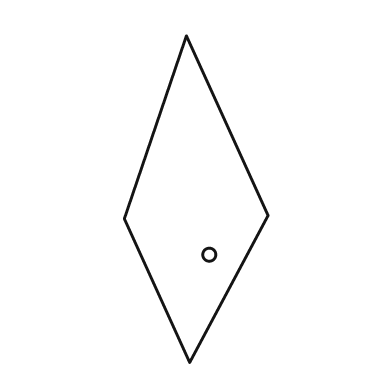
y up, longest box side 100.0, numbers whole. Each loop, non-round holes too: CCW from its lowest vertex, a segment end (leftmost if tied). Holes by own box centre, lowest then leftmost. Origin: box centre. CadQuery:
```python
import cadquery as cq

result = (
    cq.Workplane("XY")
    .moveTo(-2.0, -50.0)
    .lineTo(22.0, -5.0)
    .lineTo(-3.0, 50.0)
    .lineTo(-22.0, -6.0)
    .close()
    .moveTo(4.0, -17.0)
    .circle(2.0)
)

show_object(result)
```